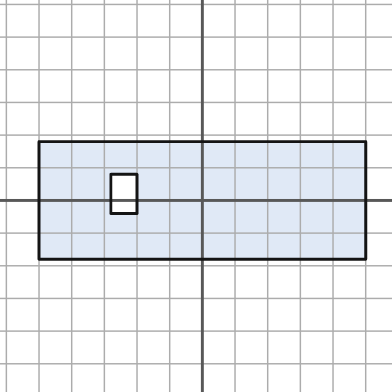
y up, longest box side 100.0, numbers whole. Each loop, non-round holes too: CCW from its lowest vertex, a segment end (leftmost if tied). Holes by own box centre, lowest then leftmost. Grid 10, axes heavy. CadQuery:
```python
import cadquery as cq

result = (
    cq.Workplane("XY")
    .moveTo(-50.0, -18.0)
    .lineTo(50.0, -18.0)
    .lineTo(50.0, 18.0)
    .lineTo(-50.0, 18.0)
    .close()
    .moveTo(-28.0, -4.0)
    .lineTo(-20.0, -4.0)
    .lineTo(-20.0, 8.0)
    .lineTo(-28.0, 8.0)
    .close()
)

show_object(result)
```